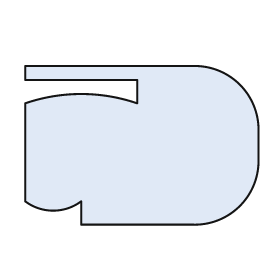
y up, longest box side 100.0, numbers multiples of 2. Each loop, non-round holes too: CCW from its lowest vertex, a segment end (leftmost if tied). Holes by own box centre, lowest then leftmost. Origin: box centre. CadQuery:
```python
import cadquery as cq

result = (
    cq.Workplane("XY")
    .moveTo(-26.0, -34.0)
    .lineTo(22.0, -34.0)
    .threePointArc((42.0, -26.0), (50.0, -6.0))
    .lineTo(50.0, 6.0)
    .threePointArc((42.0, 26.0), (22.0, 34.0))
    .lineTo(-50.0, 34.0)
    .lineTo(-50.0, 28.0)
    .lineTo(-2.0, 28.0)
    .lineTo(-2.0, 18.0)
    .threePointArc((-26.0, 22.0), (-50.0, 18.0))
    .lineTo(-50.0, -24.0)
    .threePointArc((-38.0, -28.0), (-26.0, -24.0))
    .close()
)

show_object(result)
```